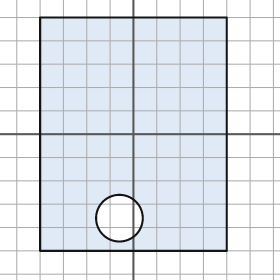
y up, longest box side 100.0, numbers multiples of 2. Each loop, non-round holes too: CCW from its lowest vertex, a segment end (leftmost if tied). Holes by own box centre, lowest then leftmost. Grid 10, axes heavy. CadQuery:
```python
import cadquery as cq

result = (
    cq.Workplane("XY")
    .moveTo(-40.0, -50.0)
    .lineTo(40.0, -50.0)
    .lineTo(40.0, 50.0)
    .lineTo(-40.0, 50.0)
    .close()
    .moveTo(-6.0, -36.0)
    .circle(10.0)
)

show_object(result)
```